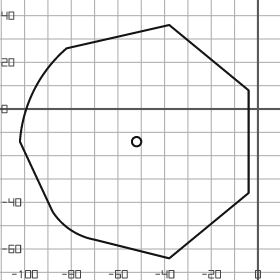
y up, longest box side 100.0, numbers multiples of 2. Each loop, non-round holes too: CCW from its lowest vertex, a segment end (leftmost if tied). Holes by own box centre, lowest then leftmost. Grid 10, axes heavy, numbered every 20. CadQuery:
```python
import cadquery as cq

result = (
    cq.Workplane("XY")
    .moveTo(-38.0, -64.0)
    .lineTo(-4.0, -36.0)
    .lineTo(-4.0, 8.0)
    .lineTo(-38.0, 36.0)
    .lineTo(-82.0, 26.0)
    .threePointArc((-96.0, 8.0), (-102.0, -14.0))
    .lineTo(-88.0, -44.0)
    .threePointArc((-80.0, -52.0), (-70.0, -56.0))
    .close()
    .moveTo(-52.0, -14.0)
    .circle(2.0)
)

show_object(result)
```